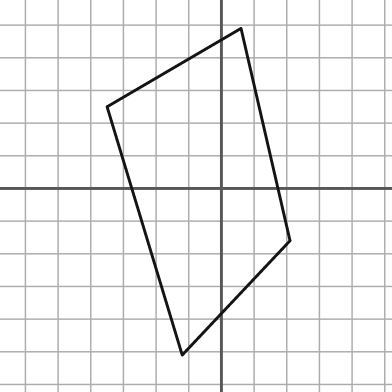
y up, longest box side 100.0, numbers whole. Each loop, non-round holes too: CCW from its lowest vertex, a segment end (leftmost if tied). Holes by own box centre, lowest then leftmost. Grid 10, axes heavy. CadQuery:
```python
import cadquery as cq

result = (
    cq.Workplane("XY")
    .moveTo(-12.0, -51.0)
    .lineTo(21.0, -16.0)
    .lineTo(6.0, 49.0)
    .lineTo(-35.0, 25.0)
    .close()
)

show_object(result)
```